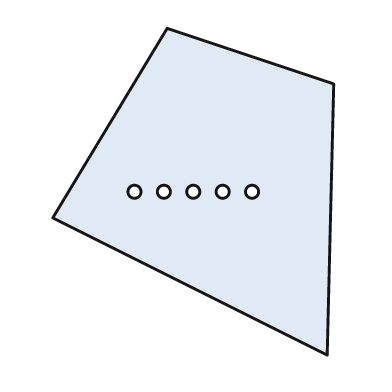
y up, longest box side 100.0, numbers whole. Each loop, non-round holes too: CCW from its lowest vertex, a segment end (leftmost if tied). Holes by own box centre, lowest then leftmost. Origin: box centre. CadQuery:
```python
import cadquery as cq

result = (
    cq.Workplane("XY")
    .moveTo(41.0, -50.0)
    .lineTo(43.0, 33.0)
    .lineTo(-8.0, 50.0)
    .lineTo(-43.0, -8.0)
    .close()
    .moveTo(-18.0, 0.0)
    .circle(2.0)
    .moveTo(-9.0, 0.0)
    .circle(2.0)
    .moveTo(0.0, 0.0)
    .circle(2.0)
    .moveTo(9.0, 0.0)
    .circle(2.0)
    .moveTo(18.0, 0.0)
    .circle(2.0)
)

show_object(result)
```